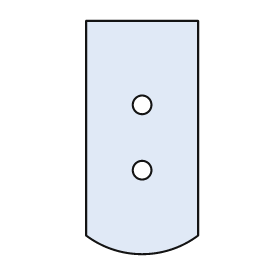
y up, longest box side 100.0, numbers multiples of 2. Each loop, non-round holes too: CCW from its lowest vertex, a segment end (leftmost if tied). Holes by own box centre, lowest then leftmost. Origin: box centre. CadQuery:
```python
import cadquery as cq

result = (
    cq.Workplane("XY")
    .moveTo(-24.0, -42.0)
    .threePointArc((0.0, -50.0), (24.0, -42.0))
    .lineTo(24.0, 50.0)
    .lineTo(-24.0, 50.0)
    .close()
    .moveTo(0.0, -14.0)
    .circle(4.0)
    .moveTo(0.0, 14.0)
    .circle(4.0)
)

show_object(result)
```